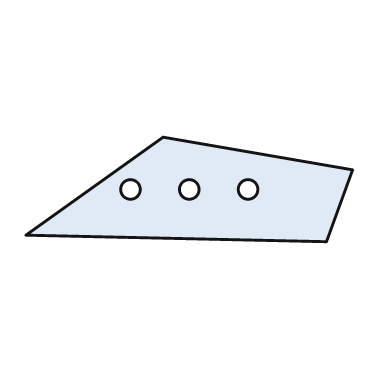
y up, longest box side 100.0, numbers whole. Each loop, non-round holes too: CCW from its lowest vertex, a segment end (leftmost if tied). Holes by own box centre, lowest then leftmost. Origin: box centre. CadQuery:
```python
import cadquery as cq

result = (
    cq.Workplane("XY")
    .moveTo(42.0, -16.0)
    .lineTo(50.0, 6.0)
    .lineTo(-8.0, 16.0)
    .lineTo(-50.0, -14.0)
    .close()
    .moveTo(-18.0, 0.0)
    .circle(3.0)
    .moveTo(0.0, 0.0)
    .circle(3.0)
    .moveTo(18.0, 0.0)
    .circle(3.0)
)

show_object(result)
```